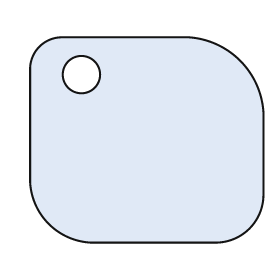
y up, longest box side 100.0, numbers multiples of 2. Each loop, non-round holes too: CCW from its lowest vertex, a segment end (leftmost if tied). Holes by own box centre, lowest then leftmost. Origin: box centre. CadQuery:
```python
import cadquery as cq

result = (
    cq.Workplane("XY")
    .moveTo(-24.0, -44.0)
    .lineTo(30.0, -44.0)
    .threePointArc((44.0, -38.0), (50.0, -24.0))
    .lineTo(50.0, 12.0)
    .threePointArc((40.0, 34.0), (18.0, 44.0))
    .lineTo(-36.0, 44.0)
    .threePointArc((-46.0, 40.0), (-50.0, 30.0))
    .lineTo(-50.0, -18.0)
    .threePointArc((-42.0, -36.0), (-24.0, -44.0))
    .close()
    .moveTo(-28.0, 28.0)
    .circle(8.0)
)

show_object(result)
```